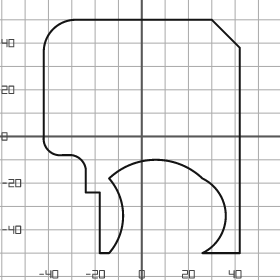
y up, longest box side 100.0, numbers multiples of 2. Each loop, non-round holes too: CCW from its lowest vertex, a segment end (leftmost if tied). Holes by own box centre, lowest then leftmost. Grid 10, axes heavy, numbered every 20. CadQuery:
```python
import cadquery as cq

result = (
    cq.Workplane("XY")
    .moveTo(-18.0, -50.0)
    .lineTo(-14.0, -50.0)
    .threePointArc((-8.0, -34.0), (-14.0, -18.0))
    .threePointArc((6.0, -10.0), (26.0, -18.0))
    .threePointArc((36.0, -34.0), (26.0, -50.0))
    .lineTo(42.0, -50.0)
    .lineTo(42.0, 38.0)
    .lineTo(30.0, 50.0)
    .lineTo(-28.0, 50.0)
    .threePointArc((-38.0, 46.0), (-42.0, 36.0))
    .lineTo(-42.0, 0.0)
    .threePointArc((-40.0, -6.0), (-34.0, -8.0))
    .lineTo(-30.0, -8.0)
    .threePointArc((-26.0, -10.0), (-24.0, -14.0))
    .lineTo(-24.0, -24.0)
    .lineTo(-18.0, -24.0)
    .close()
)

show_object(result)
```